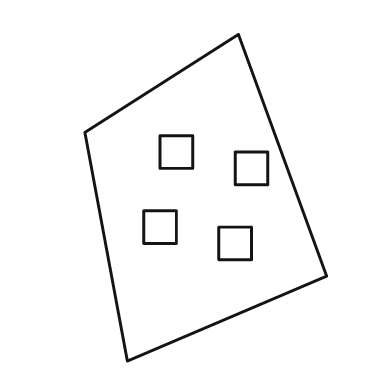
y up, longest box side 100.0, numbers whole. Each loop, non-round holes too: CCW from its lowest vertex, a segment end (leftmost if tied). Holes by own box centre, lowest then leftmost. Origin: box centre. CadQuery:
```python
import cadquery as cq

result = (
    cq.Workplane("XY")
    .moveTo(-24.0, -50.0)
    .lineTo(37.0, -24.0)
    .lineTo(10.0, 50.0)
    .lineTo(-37.0, 20.0)
    .close()
    .moveTo(4.0, -19.0)
    .lineTo(14.0, -19.0)
    .lineTo(14.0, -9.0)
    .lineTo(4.0, -9.0)
    .close()
    .moveTo(-19.0, -14.0)
    .lineTo(-9.0, -14.0)
    .lineTo(-9.0, -4.0)
    .lineTo(-19.0, -4.0)
    .close()
    .moveTo(9.0, 4.0)
    .lineTo(19.0, 4.0)
    .lineTo(19.0, 14.0)
    .lineTo(9.0, 14.0)
    .close()
    .moveTo(-14.0, 9.0)
    .lineTo(-4.0, 9.0)
    .lineTo(-4.0, 19.0)
    .lineTo(-14.0, 19.0)
    .close()
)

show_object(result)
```